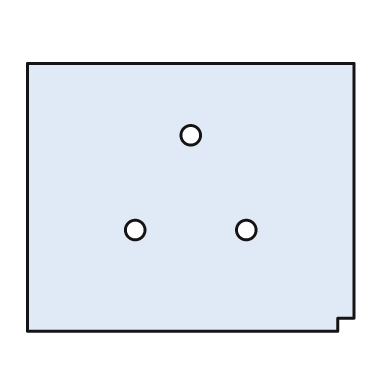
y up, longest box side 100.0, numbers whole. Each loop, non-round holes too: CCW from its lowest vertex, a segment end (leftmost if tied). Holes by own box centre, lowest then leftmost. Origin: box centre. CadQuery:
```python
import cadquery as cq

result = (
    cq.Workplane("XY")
    .moveTo(-50.0, -41.0)
    .lineTo(45.0, -41.0)
    .lineTo(45.0, -37.0)
    .lineTo(50.0, -37.0)
    .lineTo(50.0, 41.0)
    .lineTo(-50.0, 41.0)
    .close()
    .moveTo(-17.0, -10.0)
    .circle(3.0)
    .moveTo(17.0, -10.0)
    .circle(3.0)
    .moveTo(0.0, 19.0)
    .circle(3.0)
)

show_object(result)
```